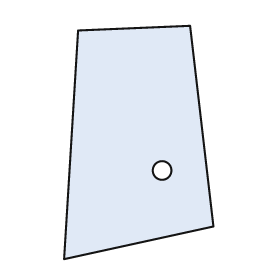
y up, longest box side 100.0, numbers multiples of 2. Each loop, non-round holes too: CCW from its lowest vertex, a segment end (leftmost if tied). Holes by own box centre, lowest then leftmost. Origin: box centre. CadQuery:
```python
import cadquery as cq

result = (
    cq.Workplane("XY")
    .moveTo(-32.0, -50.0)
    .lineTo(32.0, -36.0)
    .lineTo(22.0, 50.0)
    .lineTo(-26.0, 48.0)
    .close()
    .moveTo(10.0, -12.0)
    .circle(4.0)
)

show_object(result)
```